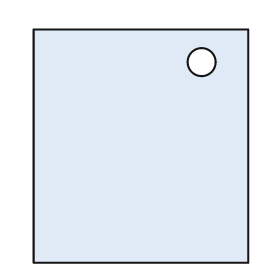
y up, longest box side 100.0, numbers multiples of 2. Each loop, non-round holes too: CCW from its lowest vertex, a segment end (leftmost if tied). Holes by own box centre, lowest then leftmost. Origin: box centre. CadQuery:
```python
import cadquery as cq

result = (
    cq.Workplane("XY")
    .moveTo(-46.0, -50.0)
    .lineTo(46.0, -50.0)
    .lineTo(46.0, 50.0)
    .lineTo(-46.0, 50.0)
    .close()
    .moveTo(26.0, 36.0)
    .circle(6.0)
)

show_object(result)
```